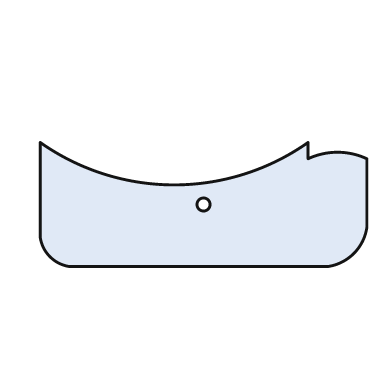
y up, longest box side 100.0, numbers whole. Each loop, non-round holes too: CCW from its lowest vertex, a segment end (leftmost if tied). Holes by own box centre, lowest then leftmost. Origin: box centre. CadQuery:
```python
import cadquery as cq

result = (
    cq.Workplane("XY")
    .moveTo(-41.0, -19.0)
    .lineTo(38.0, -19.0)
    .threePointArc((46.0, -15.0), (50.0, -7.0))
    .lineTo(50.0, 14.0)
    .threePointArc((41.0, 16.0), (32.0, 14.0))
    .lineTo(32.0, 19.0)
    .threePointArc((-9.0, 6.0), (-50.0, 19.0))
    .lineTo(-50.0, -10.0)
    .threePointArc((-47.0, -16.0), (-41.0, -19.0))
    .close()
    .moveTo(0.0, 0.0)
    .circle(2.0)
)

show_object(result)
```